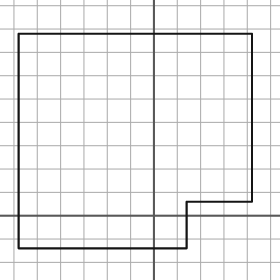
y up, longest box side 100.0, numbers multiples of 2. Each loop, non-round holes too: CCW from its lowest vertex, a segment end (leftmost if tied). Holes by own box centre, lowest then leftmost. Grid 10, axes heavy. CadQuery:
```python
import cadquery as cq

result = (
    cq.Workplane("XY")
    .moveTo(-58.0, -14.0)
    .lineTo(14.0, -14.0)
    .lineTo(14.0, 6.0)
    .lineTo(42.0, 6.0)
    .lineTo(42.0, 78.0)
    .lineTo(-58.0, 78.0)
    .close()
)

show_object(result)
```